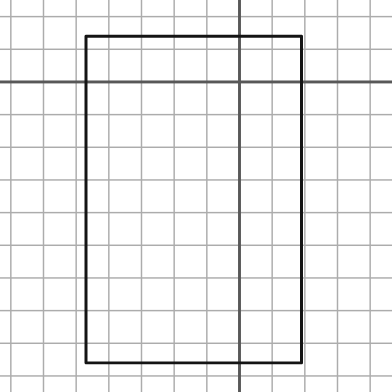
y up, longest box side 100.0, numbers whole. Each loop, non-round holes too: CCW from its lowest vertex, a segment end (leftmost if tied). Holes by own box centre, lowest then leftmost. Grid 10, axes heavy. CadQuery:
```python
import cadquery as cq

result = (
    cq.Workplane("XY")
    .moveTo(-47.0, -86.0)
    .lineTo(19.0, -86.0)
    .lineTo(19.0, 14.0)
    .lineTo(-47.0, 14.0)
    .close()
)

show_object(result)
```